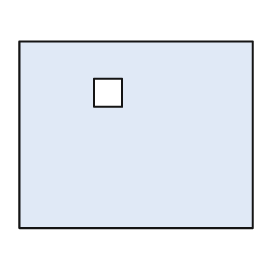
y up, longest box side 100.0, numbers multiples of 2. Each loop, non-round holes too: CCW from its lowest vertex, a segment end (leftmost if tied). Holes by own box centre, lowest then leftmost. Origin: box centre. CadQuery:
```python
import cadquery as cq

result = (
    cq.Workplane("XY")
    .moveTo(-50.0, -40.0)
    .lineTo(50.0, -40.0)
    .lineTo(50.0, 40.0)
    .lineTo(-50.0, 40.0)
    .close()
    .moveTo(-18.0, 12.0)
    .lineTo(-6.0, 12.0)
    .lineTo(-6.0, 24.0)
    .lineTo(-18.0, 24.0)
    .close()
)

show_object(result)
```